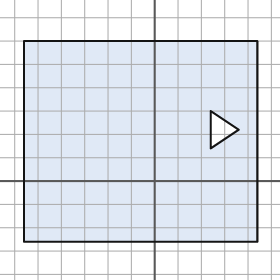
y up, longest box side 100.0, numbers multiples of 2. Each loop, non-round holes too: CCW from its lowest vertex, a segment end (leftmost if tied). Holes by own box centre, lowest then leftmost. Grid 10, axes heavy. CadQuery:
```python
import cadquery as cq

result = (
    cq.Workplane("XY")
    .moveTo(-56.0, -26.0)
    .lineTo(44.0, -26.0)
    .lineTo(44.0, 60.0)
    .lineTo(-56.0, 60.0)
    .close()
    .moveTo(24.0, 14.0)
    .lineTo(36.0, 22.0)
    .lineTo(24.0, 30.0)
    .close()
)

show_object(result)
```